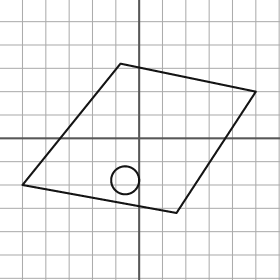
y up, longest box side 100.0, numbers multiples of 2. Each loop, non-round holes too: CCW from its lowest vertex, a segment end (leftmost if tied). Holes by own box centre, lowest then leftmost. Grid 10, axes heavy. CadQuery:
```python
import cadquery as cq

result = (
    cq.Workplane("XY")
    .moveTo(16.0, -32.0)
    .lineTo(50.0, 20.0)
    .lineTo(-8.0, 32.0)
    .lineTo(-50.0, -20.0)
    .close()
    .moveTo(-6.0, -18.0)
    .circle(6.0)
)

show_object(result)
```